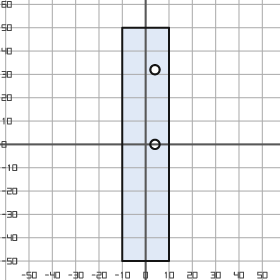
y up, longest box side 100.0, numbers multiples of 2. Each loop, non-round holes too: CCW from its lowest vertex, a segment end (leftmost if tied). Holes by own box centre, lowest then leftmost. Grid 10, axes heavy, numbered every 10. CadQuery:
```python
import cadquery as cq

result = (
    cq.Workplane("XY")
    .moveTo(-10.0, -50.0)
    .lineTo(10.0, -50.0)
    .lineTo(10.0, 50.0)
    .lineTo(-10.0, 50.0)
    .close()
    .moveTo(4.0, 0.0)
    .circle(2.0)
    .moveTo(4.0, 32.0)
    .circle(2.0)
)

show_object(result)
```